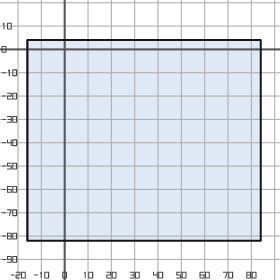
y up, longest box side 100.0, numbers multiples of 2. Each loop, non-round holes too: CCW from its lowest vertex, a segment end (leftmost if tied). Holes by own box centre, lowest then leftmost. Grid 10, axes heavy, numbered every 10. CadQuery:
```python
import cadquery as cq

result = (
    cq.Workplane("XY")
    .moveTo(-16.0, -82.0)
    .lineTo(84.0, -82.0)
    .lineTo(84.0, 4.0)
    .lineTo(-16.0, 4.0)
    .close()
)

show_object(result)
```